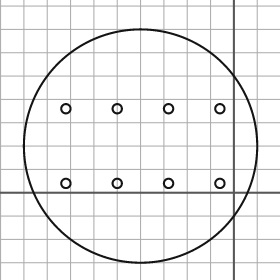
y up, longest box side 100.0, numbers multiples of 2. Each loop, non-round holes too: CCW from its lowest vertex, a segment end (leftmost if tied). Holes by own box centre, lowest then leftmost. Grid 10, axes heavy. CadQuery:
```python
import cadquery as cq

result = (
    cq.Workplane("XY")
    .moveTo(-40.0, 20.0)
    .circle(50.0)
    .moveTo(-72.0, 4.0)
    .circle(2.0)
    .moveTo(-50.0, 4.0)
    .circle(2.0)
    .moveTo(-28.0, 4.0)
    .circle(2.0)
    .moveTo(-6.0, 4.0)
    .circle(2.0)
    .moveTo(-72.0, 36.0)
    .circle(2.0)
    .moveTo(-50.0, 36.0)
    .circle(2.0)
    .moveTo(-28.0, 36.0)
    .circle(2.0)
    .moveTo(-6.0, 36.0)
    .circle(2.0)
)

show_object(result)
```